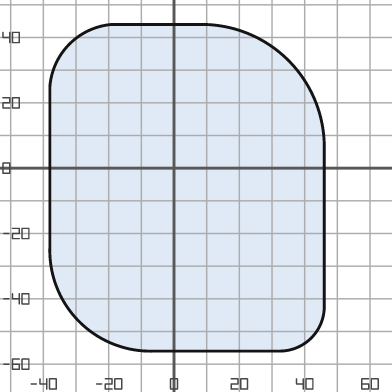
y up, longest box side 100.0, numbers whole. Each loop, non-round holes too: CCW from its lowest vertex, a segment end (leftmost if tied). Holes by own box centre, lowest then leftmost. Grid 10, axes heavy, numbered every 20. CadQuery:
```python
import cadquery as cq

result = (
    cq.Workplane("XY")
    .moveTo(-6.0, -56.0)
    .lineTo(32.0, -56.0)
    .threePointArc((42.0, -52.0), (46.0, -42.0))
    .lineTo(46.0, 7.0)
    .threePointArc((35.0, 33.0), (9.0, 44.0))
    .lineTo(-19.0, 44.0)
    .threePointArc((-32.0, 38.0), (-38.0, 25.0))
    .lineTo(-38.0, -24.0)
    .threePointArc((-29.0, -47.0), (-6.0, -56.0))
    .close()
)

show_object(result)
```